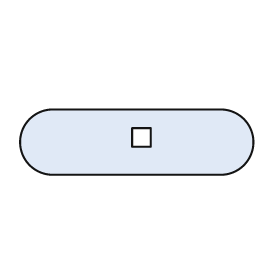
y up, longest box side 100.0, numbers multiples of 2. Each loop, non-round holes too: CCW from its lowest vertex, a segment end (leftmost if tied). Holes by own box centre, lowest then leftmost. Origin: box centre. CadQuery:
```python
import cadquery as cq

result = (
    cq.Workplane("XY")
    .moveTo(-36.0, -14.0)
    .lineTo(36.0, -14.0)
    .threePointArc((50.0, 0.0), (36.0, 14.0))
    .lineTo(-36.0, 14.0)
    .threePointArc((-50.0, 0.0), (-36.0, -14.0))
    .close()
    .moveTo(-2.0, -2.0)
    .lineTo(6.0, -2.0)
    .lineTo(6.0, 6.0)
    .lineTo(-2.0, 6.0)
    .close()
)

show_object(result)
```